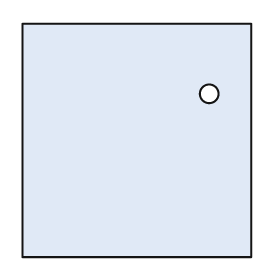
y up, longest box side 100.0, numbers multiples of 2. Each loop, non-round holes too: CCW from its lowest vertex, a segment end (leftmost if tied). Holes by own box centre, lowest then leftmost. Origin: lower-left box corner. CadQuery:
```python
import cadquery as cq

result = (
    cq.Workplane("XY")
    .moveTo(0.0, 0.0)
    .lineTo(98.0, 0.0)
    .lineTo(98.0, 100.0)
    .lineTo(0.0, 100.0)
    .close()
    .moveTo(80.0, 70.0)
    .circle(4.0)
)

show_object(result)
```